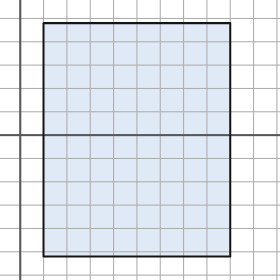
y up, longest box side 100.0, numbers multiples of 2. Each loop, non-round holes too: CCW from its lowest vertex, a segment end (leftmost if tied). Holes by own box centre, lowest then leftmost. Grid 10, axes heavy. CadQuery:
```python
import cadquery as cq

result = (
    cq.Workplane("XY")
    .moveTo(10.0, -52.0)
    .lineTo(90.0, -52.0)
    .lineTo(90.0, 48.0)
    .lineTo(10.0, 48.0)
    .close()
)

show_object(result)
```